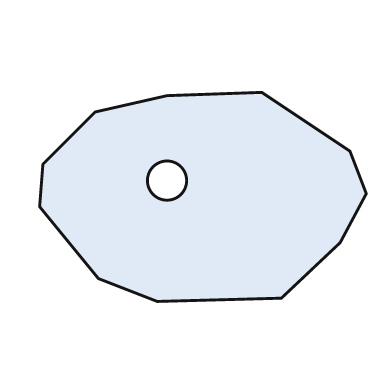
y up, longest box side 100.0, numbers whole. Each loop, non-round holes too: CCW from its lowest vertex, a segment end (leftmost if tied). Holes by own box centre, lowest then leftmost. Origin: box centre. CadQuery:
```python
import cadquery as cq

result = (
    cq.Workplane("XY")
    .moveTo(-14.0, -32.0)
    .lineTo(24.0, -31.0)
    .lineTo(42.0, -14.0)
    .lineTo(50.0, 1.0)
    .lineTo(45.0, 14.0)
    .lineTo(18.0, 32.0)
    .lineTo(-11.0, 31.0)
    .lineTo(-33.0, 26.0)
    .lineTo(-49.0, 10.0)
    .lineTo(-50.0, -3.0)
    .lineTo(-32.0, -25.0)
    .close()
    .moveTo(-11.0, 5.0)
    .circle(6.0)
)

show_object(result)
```